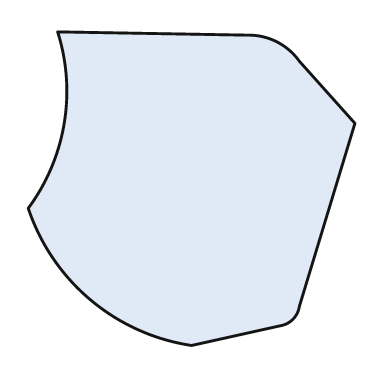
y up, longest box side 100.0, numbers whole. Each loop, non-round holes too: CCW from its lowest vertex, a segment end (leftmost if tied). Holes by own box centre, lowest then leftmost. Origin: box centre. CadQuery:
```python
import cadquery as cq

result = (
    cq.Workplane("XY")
    .moveTo(0.0, -48.0)
    .lineTo(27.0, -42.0)
    .threePointArc((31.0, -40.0), (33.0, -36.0))
    .lineTo(50.0, 20.0)
    .lineTo(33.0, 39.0)
    .threePointArc((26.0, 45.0), (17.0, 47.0))
    .lineTo(-41.0, 48.0)
    .threePointArc((-39.0, 20.0), (-50.0, -6.0))
    .threePointArc((-31.0, -34.0), (0.0, -48.0))
    .close()
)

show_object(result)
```